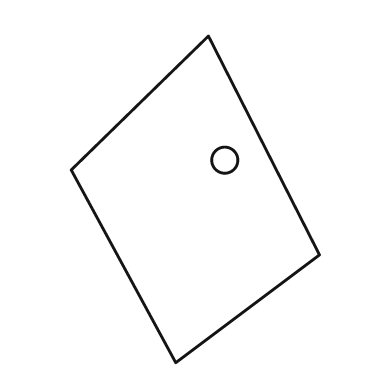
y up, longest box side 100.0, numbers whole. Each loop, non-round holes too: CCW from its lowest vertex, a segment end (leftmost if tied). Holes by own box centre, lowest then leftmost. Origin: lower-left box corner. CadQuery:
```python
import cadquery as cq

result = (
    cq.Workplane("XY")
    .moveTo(32.0, 0.0)
    .lineTo(76.0, 33.0)
    .lineTo(42.0, 100.0)
    .lineTo(0.0, 59.0)
    .close()
    .moveTo(47.0, 62.0)
    .circle(4.0)
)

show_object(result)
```